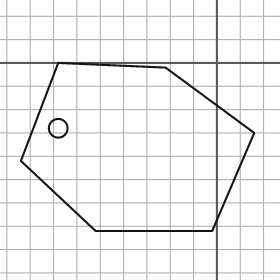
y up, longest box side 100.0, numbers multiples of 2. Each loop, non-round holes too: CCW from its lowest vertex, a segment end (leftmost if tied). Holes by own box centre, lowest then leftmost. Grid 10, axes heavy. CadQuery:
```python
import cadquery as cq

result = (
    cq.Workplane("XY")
    .moveTo(-52.0, -72.0)
    .lineTo(-2.0, -72.0)
    .lineTo(16.0, -30.0)
    .lineTo(-22.0, -2.0)
    .lineTo(-68.0, 0.0)
    .lineTo(-84.0, -42.0)
    .close()
    .moveTo(-68.0, -28.0)
    .circle(4.0)
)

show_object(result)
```